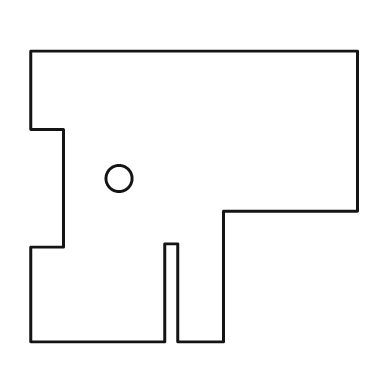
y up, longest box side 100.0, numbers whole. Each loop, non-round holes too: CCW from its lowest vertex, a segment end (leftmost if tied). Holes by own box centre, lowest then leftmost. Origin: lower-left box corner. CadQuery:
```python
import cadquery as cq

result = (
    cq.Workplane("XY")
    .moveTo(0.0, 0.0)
    .lineTo(41.0, 0.0)
    .lineTo(41.0, 30.0)
    .lineTo(45.0, 30.0)
    .lineTo(45.0, 0.0)
    .lineTo(59.0, 0.0)
    .lineTo(59.0, 40.0)
    .lineTo(100.0, 40.0)
    .lineTo(100.0, 89.0)
    .lineTo(0.0, 89.0)
    .lineTo(0.0, 65.0)
    .lineTo(10.0, 65.0)
    .lineTo(10.0, 29.0)
    .lineTo(0.0, 29.0)
    .close()
    .moveTo(27.0, 50.0)
    .circle(4.0)
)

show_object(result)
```